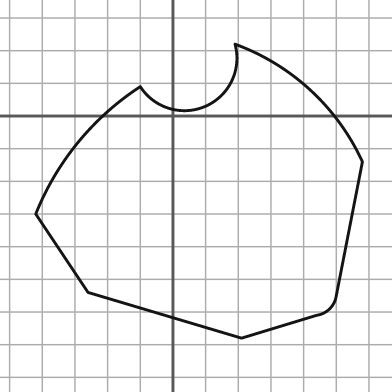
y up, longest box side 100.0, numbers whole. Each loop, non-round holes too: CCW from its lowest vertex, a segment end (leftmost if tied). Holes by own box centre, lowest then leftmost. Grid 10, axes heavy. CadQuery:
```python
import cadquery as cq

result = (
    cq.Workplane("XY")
    .moveTo(21.0, -68.0)
    .lineTo(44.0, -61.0)
    .threePointArc((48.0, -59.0), (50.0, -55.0))
    .lineTo(58.0, -14.0)
    .threePointArc((42.0, 8.0), (19.0, 22.0))
    .threePointArc((10.0, 3.0), (-10.0, 9.0))
    .threePointArc((-29.0, -8.0), (-42.0, -30.0))
    .lineTo(-26.0, -54.0)
    .close()
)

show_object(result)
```